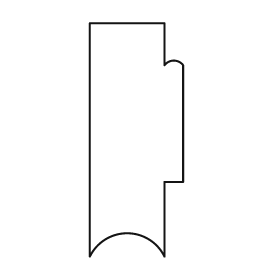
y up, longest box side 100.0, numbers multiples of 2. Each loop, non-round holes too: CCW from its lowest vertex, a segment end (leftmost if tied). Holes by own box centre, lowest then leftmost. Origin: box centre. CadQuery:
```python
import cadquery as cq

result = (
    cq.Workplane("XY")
    .moveTo(-20.0, -50.0)
    .threePointArc((-4.0, -40.0), (12.0, -50.0))
    .lineTo(12.0, -18.0)
    .lineTo(20.0, -18.0)
    .lineTo(20.0, 32.0)
    .threePointArc((16.0, 34.0), (12.0, 32.0))
    .lineTo(12.0, 50.0)
    .lineTo(-20.0, 50.0)
    .close()
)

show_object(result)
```